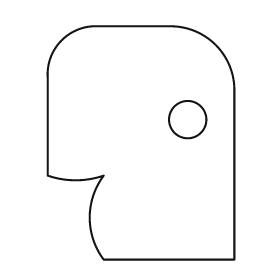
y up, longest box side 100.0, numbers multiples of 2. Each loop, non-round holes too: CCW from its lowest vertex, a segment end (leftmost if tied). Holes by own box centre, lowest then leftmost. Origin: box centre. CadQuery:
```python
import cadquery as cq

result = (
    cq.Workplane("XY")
    .moveTo(-16.0, -50.0)
    .lineTo(40.0, -50.0)
    .lineTo(40.0, 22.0)
    .threePointArc((32.0, 42.0), (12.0, 50.0))
    .lineTo(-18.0, 50.0)
    .threePointArc((-34.0, 44.0), (-40.0, 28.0))
    .lineTo(-40.0, -14.0)
    .threePointArc((-28.0, -16.0), (-16.0, -14.0))
    .threePointArc((-22.0, -32.0), (-16.0, -50.0))
    .close()
    .moveTo(20.0, 10.0)
    .circle(8.0)
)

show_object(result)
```